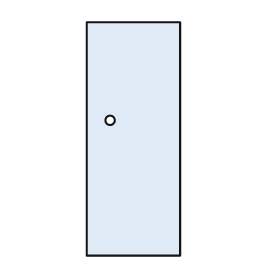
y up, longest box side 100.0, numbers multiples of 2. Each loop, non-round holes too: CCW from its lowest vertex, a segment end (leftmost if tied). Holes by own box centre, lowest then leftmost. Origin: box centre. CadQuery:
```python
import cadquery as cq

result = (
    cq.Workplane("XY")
    .moveTo(-20.0, -50.0)
    .lineTo(20.0, -50.0)
    .lineTo(20.0, 50.0)
    .lineTo(-20.0, 50.0)
    .close()
    .moveTo(-10.0, 8.0)
    .circle(2.0)
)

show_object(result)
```